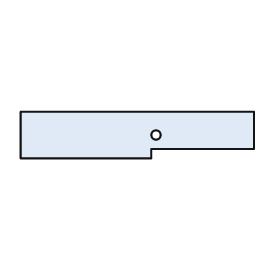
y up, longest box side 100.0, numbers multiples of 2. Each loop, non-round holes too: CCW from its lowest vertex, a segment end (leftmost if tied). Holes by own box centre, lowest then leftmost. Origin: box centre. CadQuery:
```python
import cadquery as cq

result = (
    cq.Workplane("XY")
    .moveTo(-50.0, -10.0)
    .lineTo(6.0, -10.0)
    .lineTo(6.0, -6.0)
    .lineTo(50.0, -6.0)
    .lineTo(50.0, 10.0)
    .lineTo(-50.0, 10.0)
    .close()
    .moveTo(8.0, 0.0)
    .circle(2.0)
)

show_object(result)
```